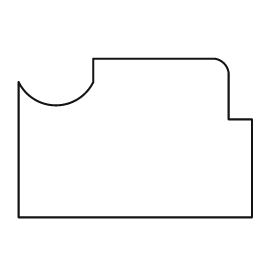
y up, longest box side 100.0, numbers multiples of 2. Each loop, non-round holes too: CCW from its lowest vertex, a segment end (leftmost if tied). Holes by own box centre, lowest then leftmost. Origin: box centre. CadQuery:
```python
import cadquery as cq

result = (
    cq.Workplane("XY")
    .moveTo(-50.0, -34.0)
    .lineTo(50.0, -34.0)
    .lineTo(50.0, 8.0)
    .lineTo(40.0, 8.0)
    .lineTo(40.0, 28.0)
    .threePointArc((38.0, 32.0), (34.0, 34.0))
    .lineTo(-18.0, 34.0)
    .lineTo(-18.0, 24.0)
    .threePointArc((-34.0, 14.0), (-50.0, 24.0))
    .close()
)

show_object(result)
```